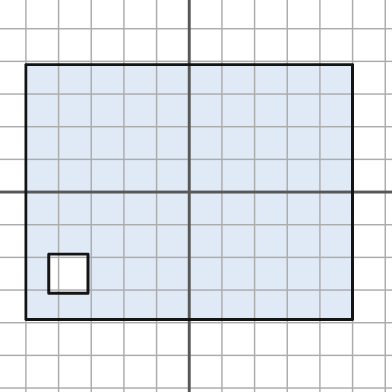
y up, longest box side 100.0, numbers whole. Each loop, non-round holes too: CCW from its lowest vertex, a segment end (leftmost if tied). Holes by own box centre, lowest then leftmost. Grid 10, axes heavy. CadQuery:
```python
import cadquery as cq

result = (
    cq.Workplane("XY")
    .moveTo(-50.0, -39.0)
    .lineTo(50.0, -39.0)
    .lineTo(50.0, 39.0)
    .lineTo(-50.0, 39.0)
    .close()
    .moveTo(-43.0, -31.0)
    .lineTo(-31.0, -31.0)
    .lineTo(-31.0, -19.0)
    .lineTo(-43.0, -19.0)
    .close()
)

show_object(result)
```